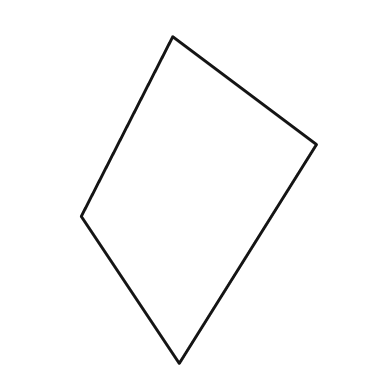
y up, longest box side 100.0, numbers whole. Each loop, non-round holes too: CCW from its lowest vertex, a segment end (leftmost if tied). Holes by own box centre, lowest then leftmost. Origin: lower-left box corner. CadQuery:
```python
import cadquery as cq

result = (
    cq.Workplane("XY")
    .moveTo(30.0, 0.0)
    .lineTo(72.0, 67.0)
    .lineTo(28.0, 100.0)
    .lineTo(0.0, 45.0)
    .close()
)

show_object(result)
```